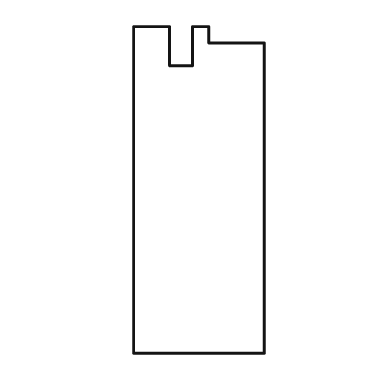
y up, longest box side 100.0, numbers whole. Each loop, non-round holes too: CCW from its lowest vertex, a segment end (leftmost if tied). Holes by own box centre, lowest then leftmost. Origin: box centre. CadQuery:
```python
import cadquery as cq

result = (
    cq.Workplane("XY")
    .moveTo(-20.0, -50.0)
    .lineTo(20.0, -50.0)
    .lineTo(20.0, 45.0)
    .lineTo(3.0, 45.0)
    .lineTo(3.0, 50.0)
    .lineTo(-2.0, 50.0)
    .lineTo(-2.0, 38.0)
    .lineTo(-9.0, 38.0)
    .lineTo(-9.0, 50.0)
    .lineTo(-20.0, 50.0)
    .close()
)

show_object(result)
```